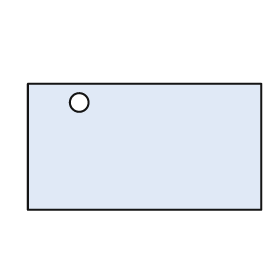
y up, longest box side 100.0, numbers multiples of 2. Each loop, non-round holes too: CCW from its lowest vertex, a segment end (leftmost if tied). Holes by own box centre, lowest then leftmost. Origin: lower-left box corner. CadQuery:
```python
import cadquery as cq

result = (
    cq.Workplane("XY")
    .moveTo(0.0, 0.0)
    .lineTo(100.0, 0.0)
    .lineTo(100.0, 54.0)
    .lineTo(0.0, 54.0)
    .close()
    .moveTo(22.0, 46.0)
    .circle(4.0)
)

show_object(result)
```